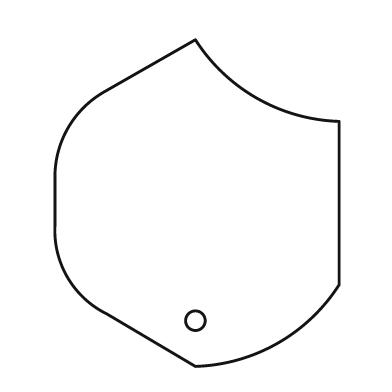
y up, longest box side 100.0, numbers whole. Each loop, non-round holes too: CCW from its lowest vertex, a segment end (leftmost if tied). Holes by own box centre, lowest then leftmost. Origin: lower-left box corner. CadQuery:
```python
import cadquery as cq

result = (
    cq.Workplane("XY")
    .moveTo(43.0, 0.0)
    .threePointArc((68.0, 7.0), (87.0, 25.0))
    .lineTo(87.0, 75.0)
    .threePointArc((62.0, 82.0), (43.0, 100.0))
    .lineTo(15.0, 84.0)
    .threePointArc((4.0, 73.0), (0.0, 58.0))
    .lineTo(0.0, 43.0)
    .threePointArc((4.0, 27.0), (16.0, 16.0))
    .close()
    .moveTo(43.0, 14.0)
    .circle(3.0)
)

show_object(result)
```